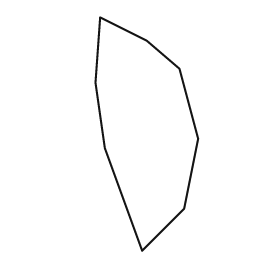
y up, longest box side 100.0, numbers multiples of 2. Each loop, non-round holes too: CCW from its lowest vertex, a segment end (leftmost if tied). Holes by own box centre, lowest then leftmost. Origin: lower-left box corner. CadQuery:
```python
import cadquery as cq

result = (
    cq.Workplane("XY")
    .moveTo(20.0, 0.0)
    .lineTo(38.0, 18.0)
    .lineTo(44.0, 48.0)
    .lineTo(36.0, 78.0)
    .lineTo(22.0, 90.0)
    .lineTo(2.0, 100.0)
    .lineTo(0.0, 72.0)
    .lineTo(4.0, 44.0)
    .close()
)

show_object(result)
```